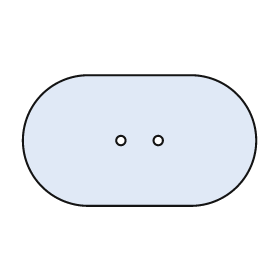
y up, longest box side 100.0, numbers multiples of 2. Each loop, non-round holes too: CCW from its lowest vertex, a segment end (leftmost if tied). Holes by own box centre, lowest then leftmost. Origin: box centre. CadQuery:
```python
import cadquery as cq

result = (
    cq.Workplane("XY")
    .moveTo(-22.0, -28.0)
    .lineTo(22.0, -28.0)
    .threePointArc((50.0, 0.0), (22.0, 28.0))
    .lineTo(-22.0, 28.0)
    .threePointArc((-50.0, 0.0), (-22.0, -28.0))
    .close()
    .moveTo(-8.0, 0.0)
    .circle(2.0)
    .moveTo(8.0, 0.0)
    .circle(2.0)
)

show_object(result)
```